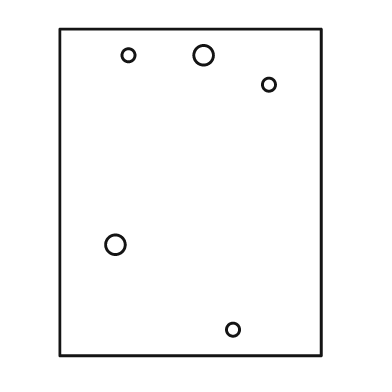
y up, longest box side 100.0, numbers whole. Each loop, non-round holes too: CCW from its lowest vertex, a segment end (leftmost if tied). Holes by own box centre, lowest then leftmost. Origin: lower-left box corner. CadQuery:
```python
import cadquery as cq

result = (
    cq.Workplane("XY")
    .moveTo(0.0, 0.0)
    .lineTo(80.0, 0.0)
    .lineTo(80.0, 100.0)
    .lineTo(0.0, 100.0)
    .close()
    .moveTo(53.0, 8.0)
    .circle(2.0)
    .moveTo(17.0, 34.0)
    .circle(3.0)
    .moveTo(64.0, 83.0)
    .circle(2.0)
    .moveTo(21.0, 92.0)
    .circle(2.0)
    .moveTo(44.0, 92.0)
    .circle(3.0)
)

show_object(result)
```